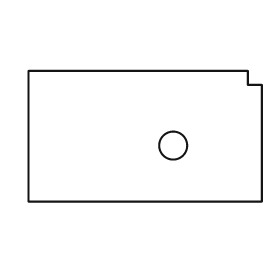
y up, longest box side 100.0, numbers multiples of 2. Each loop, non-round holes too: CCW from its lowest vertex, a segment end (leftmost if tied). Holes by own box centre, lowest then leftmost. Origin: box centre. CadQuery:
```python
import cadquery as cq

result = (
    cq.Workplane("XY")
    .moveTo(-50.0, -28.0)
    .lineTo(50.0, -28.0)
    .lineTo(50.0, 22.0)
    .lineTo(44.0, 22.0)
    .lineTo(44.0, 28.0)
    .lineTo(-50.0, 28.0)
    .close()
    .moveTo(12.0, -4.0)
    .circle(6.0)
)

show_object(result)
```